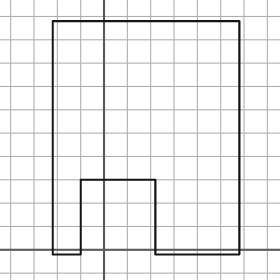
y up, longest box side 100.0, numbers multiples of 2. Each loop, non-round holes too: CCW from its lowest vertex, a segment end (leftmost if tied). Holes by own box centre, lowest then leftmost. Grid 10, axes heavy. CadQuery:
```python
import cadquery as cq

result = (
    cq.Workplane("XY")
    .moveTo(-22.0, -2.0)
    .lineTo(-10.0, -2.0)
    .lineTo(-10.0, 30.0)
    .lineTo(22.0, 30.0)
    .lineTo(22.0, -2.0)
    .lineTo(58.0, -2.0)
    .lineTo(58.0, 98.0)
    .lineTo(-22.0, 98.0)
    .close()
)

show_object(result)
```